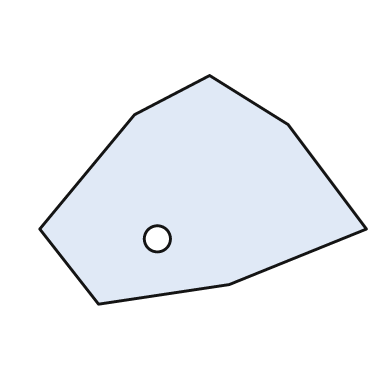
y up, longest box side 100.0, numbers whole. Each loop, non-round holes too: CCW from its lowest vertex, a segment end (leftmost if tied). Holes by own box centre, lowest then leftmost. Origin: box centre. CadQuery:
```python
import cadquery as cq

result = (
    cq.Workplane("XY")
    .moveTo(-32.0, -35.0)
    .lineTo(8.0, -29.0)
    .lineTo(50.0, -12.0)
    .lineTo(26.0, 20.0)
    .lineTo(2.0, 35.0)
    .lineTo(-21.0, 23.0)
    .lineTo(-50.0, -12.0)
    .close()
    .moveTo(-14.0, -15.0)
    .circle(4.0)
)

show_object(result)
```